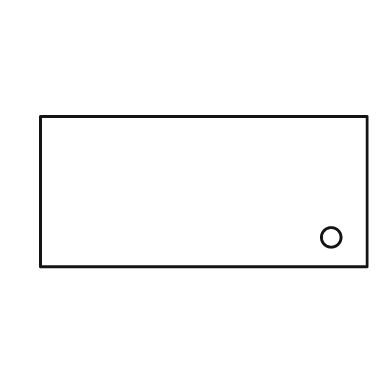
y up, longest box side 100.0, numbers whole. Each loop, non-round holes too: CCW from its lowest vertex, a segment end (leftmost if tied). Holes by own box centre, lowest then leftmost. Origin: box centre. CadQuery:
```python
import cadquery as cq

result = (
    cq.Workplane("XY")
    .moveTo(-50.0, -23.0)
    .lineTo(50.0, -23.0)
    .lineTo(50.0, 23.0)
    .lineTo(-50.0, 23.0)
    .close()
    .moveTo(39.0, -14.0)
    .circle(3.0)
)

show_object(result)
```